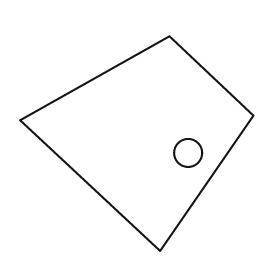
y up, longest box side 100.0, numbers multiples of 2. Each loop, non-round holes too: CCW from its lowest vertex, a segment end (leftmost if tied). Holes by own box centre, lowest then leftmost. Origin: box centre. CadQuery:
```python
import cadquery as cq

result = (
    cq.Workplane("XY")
    .moveTo(10.0, -46.0)
    .lineTo(50.0, 12.0)
    .lineTo(14.0, 46.0)
    .lineTo(-50.0, 10.0)
    .close()
    .moveTo(22.0, -4.0)
    .circle(6.0)
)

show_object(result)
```